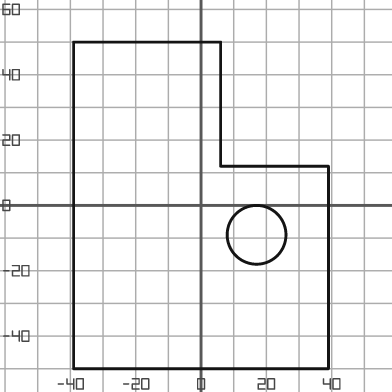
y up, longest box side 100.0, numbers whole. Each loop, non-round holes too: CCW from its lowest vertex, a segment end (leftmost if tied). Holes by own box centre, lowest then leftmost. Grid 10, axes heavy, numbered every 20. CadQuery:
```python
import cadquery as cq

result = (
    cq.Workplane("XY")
    .moveTo(-39.0, -50.0)
    .lineTo(39.0, -50.0)
    .lineTo(39.0, 12.0)
    .lineTo(6.0, 12.0)
    .lineTo(6.0, 50.0)
    .lineTo(-39.0, 50.0)
    .close()
    .moveTo(17.0, -9.0)
    .circle(9.0)
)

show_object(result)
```